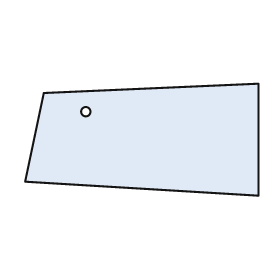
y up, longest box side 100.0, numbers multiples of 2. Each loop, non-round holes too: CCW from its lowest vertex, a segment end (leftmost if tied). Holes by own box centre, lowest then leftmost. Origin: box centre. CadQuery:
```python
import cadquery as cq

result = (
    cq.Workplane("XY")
    .moveTo(50.0, -24.0)
    .lineTo(50.0, 24.0)
    .lineTo(-42.0, 20.0)
    .lineTo(-50.0, -18.0)
    .close()
    .moveTo(-24.0, 12.0)
    .circle(2.0)
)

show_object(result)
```